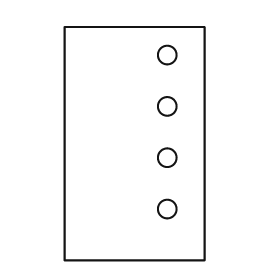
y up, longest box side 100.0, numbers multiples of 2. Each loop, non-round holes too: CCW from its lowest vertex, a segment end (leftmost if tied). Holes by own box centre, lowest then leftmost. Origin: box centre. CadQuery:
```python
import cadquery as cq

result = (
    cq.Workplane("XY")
    .moveTo(-30.0, -50.0)
    .lineTo(30.0, -50.0)
    .lineTo(30.0, 50.0)
    .lineTo(-30.0, 50.0)
    .close()
    .moveTo(14.0, -28.0)
    .circle(4.0)
    .moveTo(14.0, -6.0)
    .circle(4.0)
    .moveTo(14.0, 16.0)
    .circle(4.0)
    .moveTo(14.0, 38.0)
    .circle(4.0)
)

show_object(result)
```